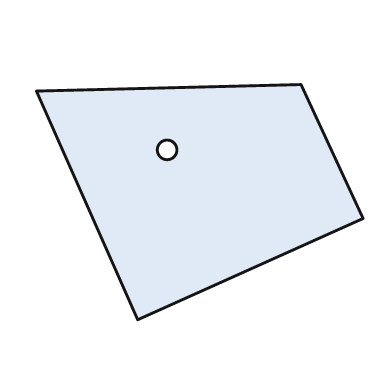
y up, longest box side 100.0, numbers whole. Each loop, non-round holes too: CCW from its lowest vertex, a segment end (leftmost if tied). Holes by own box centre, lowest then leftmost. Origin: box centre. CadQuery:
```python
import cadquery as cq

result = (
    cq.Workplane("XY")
    .moveTo(-19.0, -36.0)
    .lineTo(50.0, -5.0)
    .lineTo(31.0, 36.0)
    .lineTo(-50.0, 34.0)
    .close()
    .moveTo(-10.0, 16.0)
    .circle(3.0)
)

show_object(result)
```